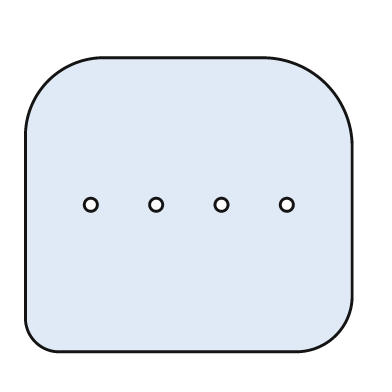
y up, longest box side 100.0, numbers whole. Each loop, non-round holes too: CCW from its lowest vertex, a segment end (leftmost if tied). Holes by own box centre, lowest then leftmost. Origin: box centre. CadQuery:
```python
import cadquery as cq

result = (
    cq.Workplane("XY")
    .moveTo(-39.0, -45.0)
    .lineTo(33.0, -45.0)
    .threePointArc((45.0, -40.0), (50.0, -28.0))
    .lineTo(50.0, 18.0)
    .threePointArc((42.0, 37.0), (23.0, 45.0))
    .lineTo(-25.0, 45.0)
    .threePointArc((-43.0, 38.0), (-50.0, 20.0))
    .lineTo(-50.0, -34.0)
    .threePointArc((-47.0, -42.0), (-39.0, -45.0))
    .close()
    .moveTo(-30.0, 0.0)
    .circle(2.0)
    .moveTo(-10.0, 0.0)
    .circle(2.0)
    .moveTo(10.0, 0.0)
    .circle(2.0)
    .moveTo(30.0, 0.0)
    .circle(2.0)
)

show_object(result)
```